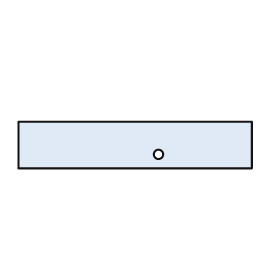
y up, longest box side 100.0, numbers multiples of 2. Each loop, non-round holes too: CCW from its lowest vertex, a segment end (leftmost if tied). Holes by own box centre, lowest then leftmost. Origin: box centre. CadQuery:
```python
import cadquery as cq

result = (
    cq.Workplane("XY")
    .moveTo(-50.0, -10.0)
    .lineTo(50.0, -10.0)
    .lineTo(50.0, 10.0)
    .lineTo(-50.0, 10.0)
    .close()
    .moveTo(10.0, -4.0)
    .circle(2.0)
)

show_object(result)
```